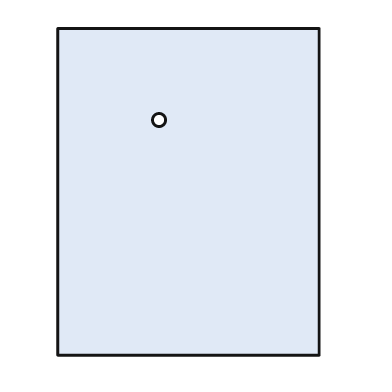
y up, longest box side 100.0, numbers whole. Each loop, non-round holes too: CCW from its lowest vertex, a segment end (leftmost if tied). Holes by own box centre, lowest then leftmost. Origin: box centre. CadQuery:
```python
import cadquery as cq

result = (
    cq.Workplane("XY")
    .moveTo(-40.0, -50.0)
    .lineTo(40.0, -50.0)
    .lineTo(40.0, 50.0)
    .lineTo(-40.0, 50.0)
    .close()
    .moveTo(-9.0, 22.0)
    .circle(2.0)
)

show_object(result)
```